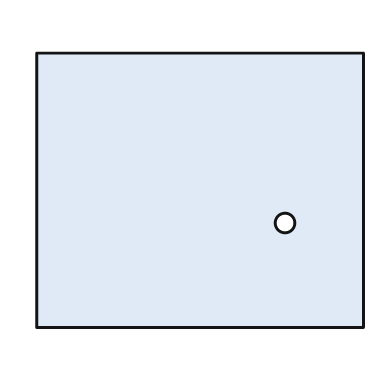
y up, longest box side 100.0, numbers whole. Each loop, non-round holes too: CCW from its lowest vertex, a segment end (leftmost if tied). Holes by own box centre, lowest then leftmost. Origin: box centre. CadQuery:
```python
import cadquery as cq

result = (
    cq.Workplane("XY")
    .moveTo(-50.0, -42.0)
    .lineTo(50.0, -42.0)
    .lineTo(50.0, 42.0)
    .lineTo(-50.0, 42.0)
    .close()
    .moveTo(26.0, -10.0)
    .circle(3.0)
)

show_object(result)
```